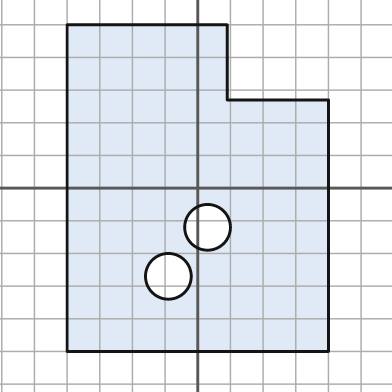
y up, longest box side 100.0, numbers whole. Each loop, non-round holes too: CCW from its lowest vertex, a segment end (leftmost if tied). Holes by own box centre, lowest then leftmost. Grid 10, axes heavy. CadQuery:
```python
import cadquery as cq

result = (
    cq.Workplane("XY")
    .moveTo(-40.0, -50.0)
    .lineTo(40.0, -50.0)
    .lineTo(40.0, 27.0)
    .lineTo(9.0, 27.0)
    .lineTo(9.0, 50.0)
    .lineTo(-40.0, 50.0)
    .close()
    .moveTo(-9.0, -27.0)
    .circle(7.0)
    .moveTo(3.0, -12.0)
    .circle(7.0)
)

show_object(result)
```